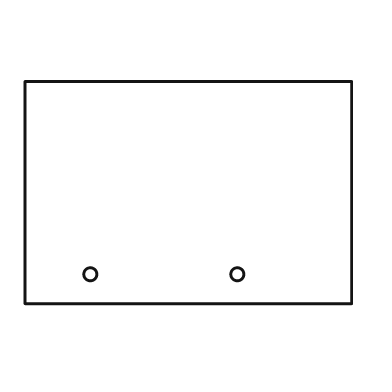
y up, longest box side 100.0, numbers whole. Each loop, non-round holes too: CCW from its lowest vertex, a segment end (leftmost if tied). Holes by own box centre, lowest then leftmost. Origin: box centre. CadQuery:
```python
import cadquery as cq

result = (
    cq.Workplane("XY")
    .moveTo(-50.0, -34.0)
    .lineTo(50.0, -34.0)
    .lineTo(50.0, 34.0)
    .lineTo(-50.0, 34.0)
    .close()
    .moveTo(-30.0, -25.0)
    .circle(2.0)
    .moveTo(15.0, -25.0)
    .circle(2.0)
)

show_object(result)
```